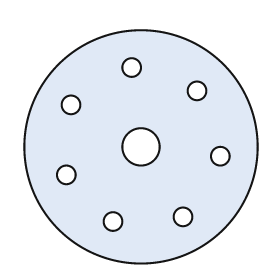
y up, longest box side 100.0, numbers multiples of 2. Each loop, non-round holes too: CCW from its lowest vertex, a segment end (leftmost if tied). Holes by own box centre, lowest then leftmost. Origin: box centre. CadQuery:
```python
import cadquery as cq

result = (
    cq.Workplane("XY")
    .moveTo(0.0, 0.0)
    .circle(50.0)
    .moveTo(-12.0, -32.0)
    .circle(4.0)
    .moveTo(18.0, -30.0)
    .circle(4.0)
    .moveTo(-32.0, -12.0)
    .circle(4.0)
    .moveTo(34.0, -4.0)
    .circle(4.0)
    .moveTo(0.0, 0.0)
    .circle(8.0)
    .moveTo(-30.0, 18.0)
    .circle(4.0)
    .moveTo(24.0, 24.0)
    .circle(4.0)
    .moveTo(-4.0, 34.0)
    .circle(4.0)
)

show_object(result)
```